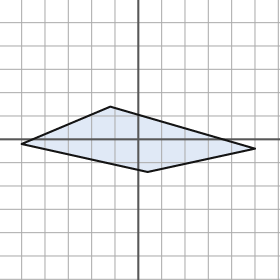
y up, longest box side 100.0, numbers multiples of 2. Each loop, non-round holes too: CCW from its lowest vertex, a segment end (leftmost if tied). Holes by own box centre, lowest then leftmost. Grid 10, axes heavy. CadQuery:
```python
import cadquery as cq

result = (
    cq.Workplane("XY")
    .moveTo(4.0, -14.0)
    .lineTo(50.0, -4.0)
    .lineTo(-12.0, 14.0)
    .lineTo(-50.0, -2.0)
    .close()
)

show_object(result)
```